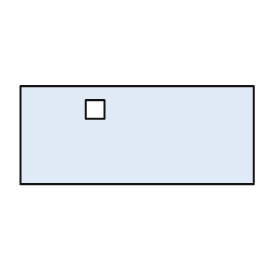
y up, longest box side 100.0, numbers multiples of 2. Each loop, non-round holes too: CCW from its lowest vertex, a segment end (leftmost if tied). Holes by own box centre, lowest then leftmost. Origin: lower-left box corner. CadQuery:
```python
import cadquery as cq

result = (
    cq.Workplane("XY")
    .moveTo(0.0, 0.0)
    .lineTo(100.0, 0.0)
    .lineTo(100.0, 42.0)
    .lineTo(0.0, 42.0)
    .close()
    .moveTo(28.0, 28.0)
    .lineTo(36.0, 28.0)
    .lineTo(36.0, 36.0)
    .lineTo(28.0, 36.0)
    .close()
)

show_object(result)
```